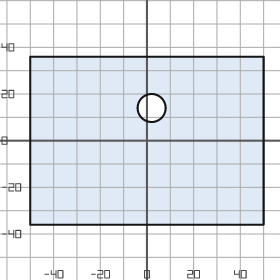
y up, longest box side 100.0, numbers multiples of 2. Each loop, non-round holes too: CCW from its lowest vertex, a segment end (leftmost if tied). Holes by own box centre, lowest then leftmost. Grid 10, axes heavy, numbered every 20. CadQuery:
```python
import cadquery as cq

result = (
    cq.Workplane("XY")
    .moveTo(-50.0, -36.0)
    .lineTo(50.0, -36.0)
    .lineTo(50.0, 36.0)
    .lineTo(-50.0, 36.0)
    .close()
    .moveTo(2.0, 14.0)
    .circle(6.0)
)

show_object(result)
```